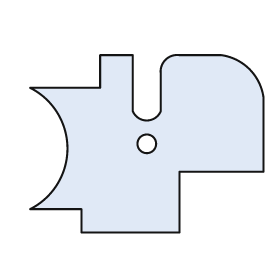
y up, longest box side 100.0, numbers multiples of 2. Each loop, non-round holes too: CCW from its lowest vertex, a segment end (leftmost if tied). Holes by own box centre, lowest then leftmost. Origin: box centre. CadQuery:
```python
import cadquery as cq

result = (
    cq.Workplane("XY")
    .moveTo(-28.0, -38.0)
    .lineTo(14.0, -38.0)
    .lineTo(14.0, -12.0)
    .lineTo(50.0, -12.0)
    .lineTo(50.0, 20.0)
    .threePointArc((44.0, 32.0), (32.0, 38.0))
    .lineTo(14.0, 38.0)
    .threePointArc((8.0, 36.0), (6.0, 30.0))
    .lineTo(6.0, 14.0)
    .threePointArc((0.0, 10.0), (-6.0, 14.0))
    .lineTo(-6.0, 38.0)
    .lineTo(-20.0, 38.0)
    .lineTo(-20.0, 24.0)
    .lineTo(-50.0, 24.0)
    .threePointArc((-34.0, -2.0), (-50.0, -28.0))
    .lineTo(-28.0, -28.0)
    .close()
    .moveTo(0.0, 0.0)
    .circle(4.0)
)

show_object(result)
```